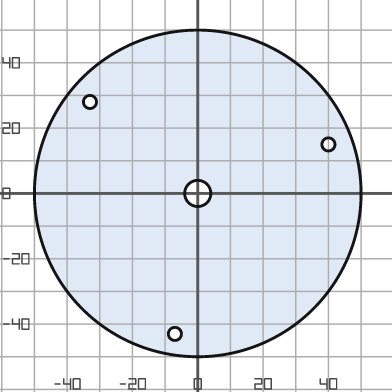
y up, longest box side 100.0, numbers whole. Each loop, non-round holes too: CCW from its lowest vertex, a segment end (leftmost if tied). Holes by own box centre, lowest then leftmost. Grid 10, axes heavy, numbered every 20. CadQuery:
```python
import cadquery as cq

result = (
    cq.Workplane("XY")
    .moveTo(0.0, 0.0)
    .circle(50.0)
    .moveTo(-7.0, -43.0)
    .circle(2.0)
    .moveTo(0.0, 0.0)
    .circle(4.0)
    .moveTo(40.0, 15.0)
    .circle(2.0)
    .moveTo(-33.0, 28.0)
    .circle(2.0)
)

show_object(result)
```